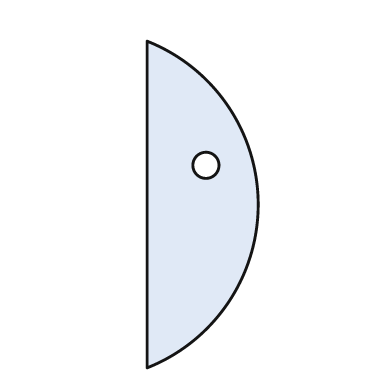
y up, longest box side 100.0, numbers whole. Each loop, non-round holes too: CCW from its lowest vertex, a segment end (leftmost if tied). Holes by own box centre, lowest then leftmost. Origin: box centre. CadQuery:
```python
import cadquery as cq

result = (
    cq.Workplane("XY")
    .moveTo(-17.0, -50.0)
    .threePointArc((17.0, 0.0), (-17.0, 50.0))
    .close()
    .moveTo(1.0, 12.0)
    .circle(4.0)
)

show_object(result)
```